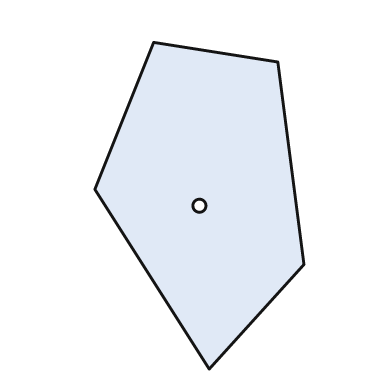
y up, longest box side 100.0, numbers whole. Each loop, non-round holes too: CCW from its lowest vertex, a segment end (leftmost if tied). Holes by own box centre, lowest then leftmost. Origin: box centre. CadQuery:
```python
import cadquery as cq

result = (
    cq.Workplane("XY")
    .moveTo(3.0, -50.0)
    .lineTo(32.0, -18.0)
    .lineTo(24.0, 44.0)
    .lineTo(-14.0, 50.0)
    .lineTo(-32.0, 5.0)
    .close()
    .moveTo(0.0, 0.0)
    .circle(2.0)
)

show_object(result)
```